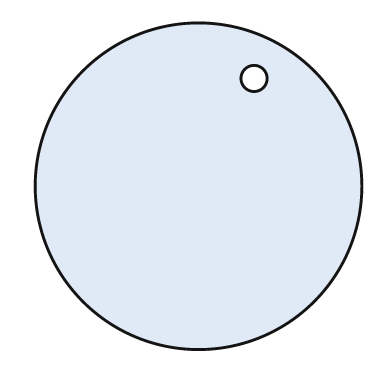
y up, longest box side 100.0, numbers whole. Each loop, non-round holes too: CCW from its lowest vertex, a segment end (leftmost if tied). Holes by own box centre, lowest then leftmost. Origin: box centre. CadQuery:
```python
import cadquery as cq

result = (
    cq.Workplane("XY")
    .moveTo(0.0, 0.0)
    .circle(50.0)
    .moveTo(17.0, 33.0)
    .circle(4.0)
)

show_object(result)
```